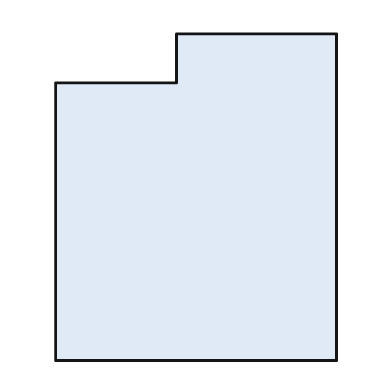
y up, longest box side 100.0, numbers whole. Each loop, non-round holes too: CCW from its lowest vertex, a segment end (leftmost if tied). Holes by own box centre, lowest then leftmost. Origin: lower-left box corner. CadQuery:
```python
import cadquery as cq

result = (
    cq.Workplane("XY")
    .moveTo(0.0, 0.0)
    .lineTo(86.0, 0.0)
    .lineTo(86.0, 100.0)
    .lineTo(37.0, 100.0)
    .lineTo(37.0, 85.0)
    .lineTo(0.0, 85.0)
    .close()
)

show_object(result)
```